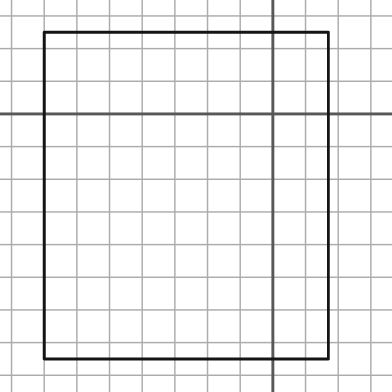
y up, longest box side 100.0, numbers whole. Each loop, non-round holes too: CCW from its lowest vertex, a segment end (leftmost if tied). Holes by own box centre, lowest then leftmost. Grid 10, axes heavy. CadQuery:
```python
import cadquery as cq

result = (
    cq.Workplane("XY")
    .moveTo(-70.0, -75.0)
    .lineTo(17.0, -75.0)
    .lineTo(17.0, 25.0)
    .lineTo(-70.0, 25.0)
    .close()
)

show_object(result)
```